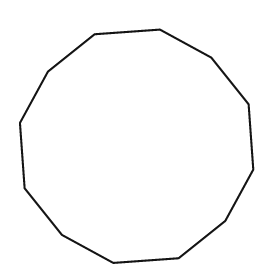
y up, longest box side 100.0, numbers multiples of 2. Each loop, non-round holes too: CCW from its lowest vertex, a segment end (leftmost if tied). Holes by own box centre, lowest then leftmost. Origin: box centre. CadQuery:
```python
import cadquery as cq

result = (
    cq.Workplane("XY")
    .moveTo(-10.0, -50.0)
    .lineTo(18.0, -48.0)
    .lineTo(38.0, -32.0)
    .lineTo(50.0, -10.0)
    .lineTo(48.0, 18.0)
    .lineTo(32.0, 38.0)
    .lineTo(10.0, 50.0)
    .lineTo(-18.0, 48.0)
    .lineTo(-38.0, 32.0)
    .lineTo(-50.0, 10.0)
    .lineTo(-48.0, -18.0)
    .lineTo(-32.0, -38.0)
    .close()
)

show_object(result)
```